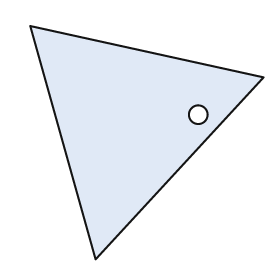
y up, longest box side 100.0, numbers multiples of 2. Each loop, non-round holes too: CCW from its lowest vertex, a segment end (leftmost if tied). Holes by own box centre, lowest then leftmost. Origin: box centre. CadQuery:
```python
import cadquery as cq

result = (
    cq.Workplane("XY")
    .moveTo(-22.0, -50.0)
    .lineTo(50.0, 28.0)
    .lineTo(-50.0, 50.0)
    .close()
    .moveTo(22.0, 12.0)
    .circle(4.0)
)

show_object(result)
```